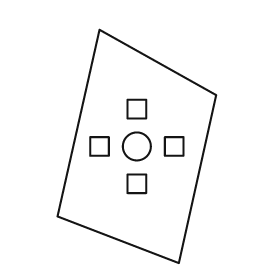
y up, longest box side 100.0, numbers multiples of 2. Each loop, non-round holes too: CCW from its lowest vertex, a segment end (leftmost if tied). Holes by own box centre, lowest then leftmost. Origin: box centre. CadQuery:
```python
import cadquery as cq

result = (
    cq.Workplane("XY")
    .moveTo(18.0, -50.0)
    .lineTo(34.0, 22.0)
    .lineTo(-16.0, 50.0)
    .lineTo(-34.0, -30.0)
    .close()
    .moveTo(-4.0, -20.0)
    .lineTo(4.0, -20.0)
    .lineTo(4.0, -12.0)
    .lineTo(-4.0, -12.0)
    .close()
    .moveTo(-20.0, -4.0)
    .lineTo(-12.0, -4.0)
    .lineTo(-12.0, 4.0)
    .lineTo(-20.0, 4.0)
    .close()
    .moveTo(0.0, 0.0)
    .circle(6.0)
    .moveTo(12.0, -4.0)
    .lineTo(20.0, -4.0)
    .lineTo(20.0, 4.0)
    .lineTo(12.0, 4.0)
    .close()
    .moveTo(-4.0, 12.0)
    .lineTo(4.0, 12.0)
    .lineTo(4.0, 20.0)
    .lineTo(-4.0, 20.0)
    .close()
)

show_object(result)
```